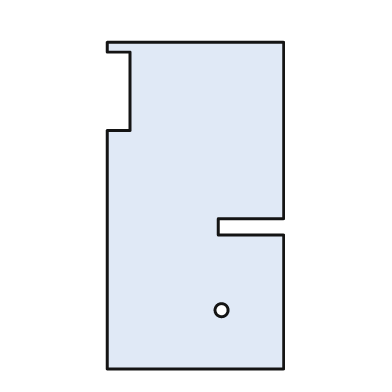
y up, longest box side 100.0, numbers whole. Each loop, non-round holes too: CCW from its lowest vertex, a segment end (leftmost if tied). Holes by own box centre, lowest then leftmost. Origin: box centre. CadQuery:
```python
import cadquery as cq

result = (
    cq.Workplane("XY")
    .moveTo(-27.0, -50.0)
    .lineTo(27.0, -50.0)
    .lineTo(27.0, -9.0)
    .lineTo(7.0, -9.0)
    .lineTo(7.0, -4.0)
    .lineTo(27.0, -4.0)
    .lineTo(27.0, 50.0)
    .lineTo(-27.0, 50.0)
    .lineTo(-27.0, 47.0)
    .lineTo(-20.0, 47.0)
    .lineTo(-20.0, 23.0)
    .lineTo(-27.0, 23.0)
    .close()
    .moveTo(8.0, -32.0)
    .circle(2.0)
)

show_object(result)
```